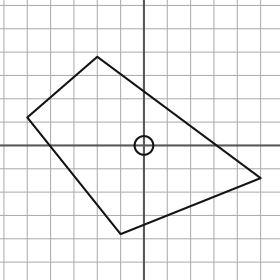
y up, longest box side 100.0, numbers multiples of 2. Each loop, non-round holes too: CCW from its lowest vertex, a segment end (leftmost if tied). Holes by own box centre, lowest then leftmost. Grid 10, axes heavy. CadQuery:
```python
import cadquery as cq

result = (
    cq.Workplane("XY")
    .moveTo(-10.0, -38.0)
    .lineTo(50.0, -14.0)
    .lineTo(-20.0, 38.0)
    .lineTo(-50.0, 12.0)
    .close()
    .moveTo(0.0, 0.0)
    .circle(4.0)
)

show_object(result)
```